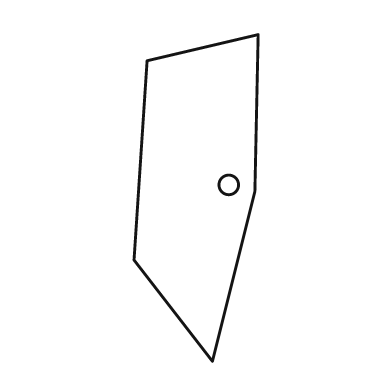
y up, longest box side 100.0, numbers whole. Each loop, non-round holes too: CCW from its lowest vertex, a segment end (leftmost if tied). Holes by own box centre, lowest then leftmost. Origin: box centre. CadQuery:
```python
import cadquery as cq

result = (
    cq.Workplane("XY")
    .moveTo(5.0, -50.0)
    .lineTo(18.0, 2.0)
    .lineTo(19.0, 50.0)
    .lineTo(-15.0, 42.0)
    .lineTo(-19.0, -19.0)
    .close()
    .moveTo(10.0, 4.0)
    .circle(3.0)
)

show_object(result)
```